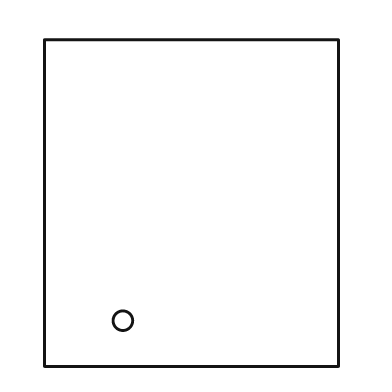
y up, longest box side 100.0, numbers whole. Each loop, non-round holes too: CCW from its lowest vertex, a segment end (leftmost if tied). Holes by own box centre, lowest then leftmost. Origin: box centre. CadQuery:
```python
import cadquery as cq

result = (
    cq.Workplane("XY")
    .moveTo(-45.0, -50.0)
    .lineTo(45.0, -50.0)
    .lineTo(45.0, 50.0)
    .lineTo(-45.0, 50.0)
    .close()
    .moveTo(-21.0, -36.0)
    .circle(3.0)
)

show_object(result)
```